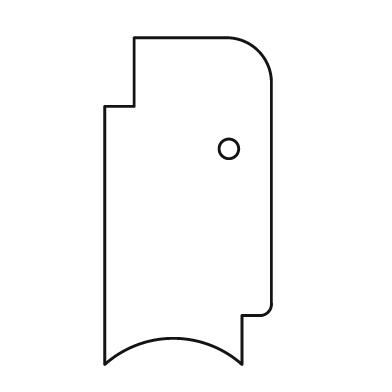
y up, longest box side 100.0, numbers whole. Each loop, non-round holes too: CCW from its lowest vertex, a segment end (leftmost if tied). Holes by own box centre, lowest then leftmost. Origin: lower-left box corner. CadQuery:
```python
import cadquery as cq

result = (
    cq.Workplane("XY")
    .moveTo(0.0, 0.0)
    .threePointArc((21.0, 8.0), (42.0, 0.0))
    .lineTo(42.0, 15.0)
    .lineTo(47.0, 15.0)
    .threePointArc((50.0, 16.0), (51.0, 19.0))
    .lineTo(51.0, 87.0)
    .threePointArc((47.0, 96.0), (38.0, 100.0))
    .lineTo(9.0, 100.0)
    .lineTo(9.0, 79.0)
    .lineTo(0.0, 79.0)
    .close()
    .moveTo(38.0, 66.0)
    .circle(3.0)
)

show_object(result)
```